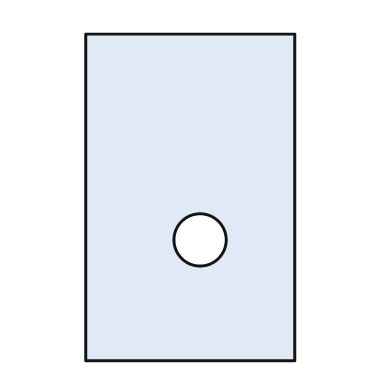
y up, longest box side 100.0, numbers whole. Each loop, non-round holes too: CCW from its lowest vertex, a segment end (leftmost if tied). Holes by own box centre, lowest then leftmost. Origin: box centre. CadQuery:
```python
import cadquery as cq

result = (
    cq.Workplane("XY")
    .moveTo(-32.0, -50.0)
    .lineTo(32.0, -50.0)
    .lineTo(32.0, 50.0)
    .lineTo(-32.0, 50.0)
    .close()
    .moveTo(3.0, -13.0)
    .circle(8.0)
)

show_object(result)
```